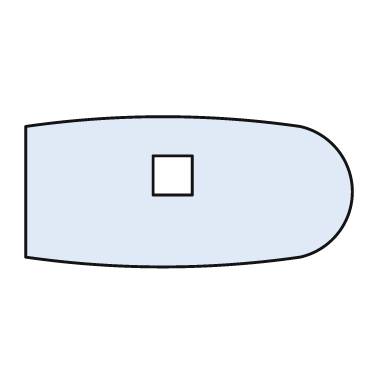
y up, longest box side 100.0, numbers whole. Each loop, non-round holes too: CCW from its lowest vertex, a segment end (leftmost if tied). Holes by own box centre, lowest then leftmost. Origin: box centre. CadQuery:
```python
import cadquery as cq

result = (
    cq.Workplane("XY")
    .moveTo(-50.0, -20.0)
    .threePointArc((-8.0, -23.0), (34.0, -20.0))
    .threePointArc((50.0, 0.0), (34.0, 20.0))
    .threePointArc((-8.0, 23.0), (-50.0, 20.0))
    .close()
    .moveTo(-11.0, -1.0)
    .lineTo(1.0, -1.0)
    .lineTo(1.0, 11.0)
    .lineTo(-11.0, 11.0)
    .close()
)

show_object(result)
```